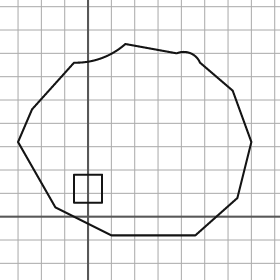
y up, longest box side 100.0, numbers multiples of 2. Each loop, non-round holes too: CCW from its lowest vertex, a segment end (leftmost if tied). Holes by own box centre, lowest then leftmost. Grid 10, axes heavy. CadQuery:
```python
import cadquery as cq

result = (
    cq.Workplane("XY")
    .moveTo(10.0, -8.0)
    .lineTo(46.0, -8.0)
    .lineTo(64.0, 8.0)
    .lineTo(70.0, 32.0)
    .lineTo(62.0, 54.0)
    .lineTo(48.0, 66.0)
    .threePointArc((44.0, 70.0), (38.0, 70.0))
    .lineTo(16.0, 74.0)
    .threePointArc((6.0, 68.0), (-6.0, 66.0))
    .lineTo(-24.0, 46.0)
    .lineTo(-30.0, 32.0)
    .lineTo(-14.0, 4.0)
    .close()
    .moveTo(-6.0, 6.0)
    .lineTo(6.0, 6.0)
    .lineTo(6.0, 18.0)
    .lineTo(-6.0, 18.0)
    .close()
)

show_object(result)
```